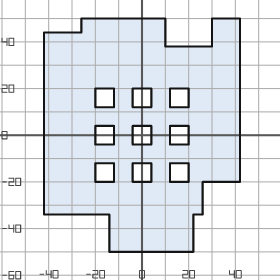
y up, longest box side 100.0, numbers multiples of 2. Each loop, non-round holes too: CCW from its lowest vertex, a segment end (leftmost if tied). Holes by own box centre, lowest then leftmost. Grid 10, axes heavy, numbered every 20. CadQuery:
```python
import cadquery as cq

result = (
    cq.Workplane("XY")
    .moveTo(-14.0, -50.0)
    .lineTo(22.0, -50.0)
    .lineTo(22.0, -34.0)
    .lineTo(26.0, -34.0)
    .lineTo(26.0, -20.0)
    .lineTo(42.0, -20.0)
    .lineTo(42.0, 50.0)
    .lineTo(30.0, 50.0)
    .lineTo(30.0, 38.0)
    .lineTo(10.0, 38.0)
    .lineTo(10.0, 50.0)
    .lineTo(-26.0, 50.0)
    .lineTo(-26.0, 44.0)
    .lineTo(-42.0, 44.0)
    .lineTo(-42.0, -34.0)
    .lineTo(-14.0, -34.0)
    .close()
    .moveTo(-20.0, -20.0)
    .lineTo(-12.0, -20.0)
    .lineTo(-12.0, -12.0)
    .lineTo(-20.0, -12.0)
    .close()
    .moveTo(-4.0, -20.0)
    .lineTo(4.0, -20.0)
    .lineTo(4.0, -12.0)
    .lineTo(-4.0, -12.0)
    .close()
    .moveTo(12.0, -20.0)
    .lineTo(20.0, -20.0)
    .lineTo(20.0, -12.0)
    .lineTo(12.0, -12.0)
    .close()
    .moveTo(-20.0, -4.0)
    .lineTo(-12.0, -4.0)
    .lineTo(-12.0, 4.0)
    .lineTo(-20.0, 4.0)
    .close()
    .moveTo(-4.0, -4.0)
    .lineTo(4.0, -4.0)
    .lineTo(4.0, 4.0)
    .lineTo(-4.0, 4.0)
    .close()
    .moveTo(12.0, -4.0)
    .lineTo(20.0, -4.0)
    .lineTo(20.0, 4.0)
    .lineTo(12.0, 4.0)
    .close()
    .moveTo(-20.0, 12.0)
    .lineTo(-12.0, 12.0)
    .lineTo(-12.0, 20.0)
    .lineTo(-20.0, 20.0)
    .close()
    .moveTo(-4.0, 12.0)
    .lineTo(4.0, 12.0)
    .lineTo(4.0, 20.0)
    .lineTo(-4.0, 20.0)
    .close()
    .moveTo(12.0, 12.0)
    .lineTo(20.0, 12.0)
    .lineTo(20.0, 20.0)
    .lineTo(12.0, 20.0)
    .close()
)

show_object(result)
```